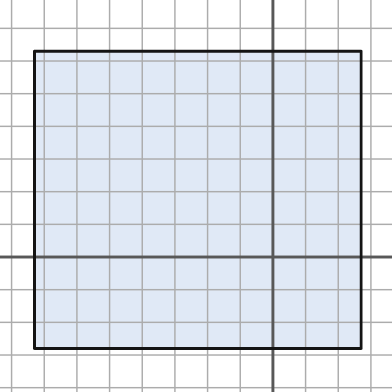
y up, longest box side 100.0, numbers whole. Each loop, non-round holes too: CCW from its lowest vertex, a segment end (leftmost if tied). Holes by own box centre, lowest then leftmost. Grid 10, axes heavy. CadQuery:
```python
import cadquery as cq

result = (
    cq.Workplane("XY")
    .moveTo(-73.0, -28.0)
    .lineTo(27.0, -28.0)
    .lineTo(27.0, 63.0)
    .lineTo(-73.0, 63.0)
    .close()
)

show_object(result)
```